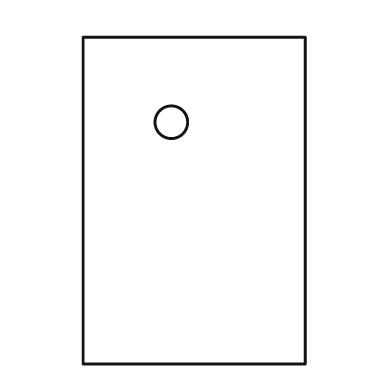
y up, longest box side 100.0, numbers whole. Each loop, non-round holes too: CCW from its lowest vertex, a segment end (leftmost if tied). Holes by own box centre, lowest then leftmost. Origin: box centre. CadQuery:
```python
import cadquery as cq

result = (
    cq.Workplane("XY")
    .moveTo(-34.0, -50.0)
    .lineTo(34.0, -50.0)
    .lineTo(34.0, 50.0)
    .lineTo(-34.0, 50.0)
    .close()
    .moveTo(-7.0, 24.0)
    .circle(5.0)
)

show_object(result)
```